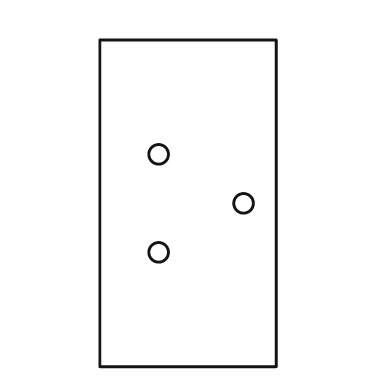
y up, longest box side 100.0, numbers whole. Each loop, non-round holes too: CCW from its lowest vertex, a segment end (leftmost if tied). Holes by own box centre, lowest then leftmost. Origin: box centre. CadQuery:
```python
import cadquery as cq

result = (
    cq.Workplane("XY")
    .moveTo(-27.0, -50.0)
    .lineTo(27.0, -50.0)
    .lineTo(27.0, 50.0)
    .lineTo(-27.0, 50.0)
    .close()
    .moveTo(-9.0, -15.0)
    .circle(3.0)
    .moveTo(17.0, 0.0)
    .circle(3.0)
    .moveTo(-9.0, 15.0)
    .circle(3.0)
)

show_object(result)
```